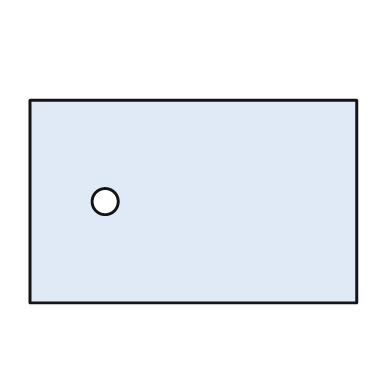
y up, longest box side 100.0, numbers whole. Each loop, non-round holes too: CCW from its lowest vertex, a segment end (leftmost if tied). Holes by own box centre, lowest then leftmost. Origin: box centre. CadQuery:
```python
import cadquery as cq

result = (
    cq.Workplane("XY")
    .moveTo(-50.0, -31.0)
    .lineTo(50.0, -31.0)
    .lineTo(50.0, 31.0)
    .lineTo(-50.0, 31.0)
    .close()
    .moveTo(-27.0, 0.0)
    .circle(4.0)
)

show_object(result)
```